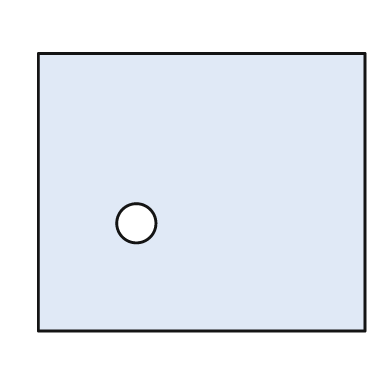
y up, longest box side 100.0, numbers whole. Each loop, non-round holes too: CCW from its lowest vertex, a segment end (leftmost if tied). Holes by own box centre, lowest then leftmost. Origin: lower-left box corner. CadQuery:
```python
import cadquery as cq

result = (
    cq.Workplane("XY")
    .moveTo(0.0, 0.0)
    .lineTo(100.0, 0.0)
    .lineTo(100.0, 85.0)
    .lineTo(0.0, 85.0)
    .close()
    .moveTo(30.0, 33.0)
    .circle(6.0)
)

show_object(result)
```